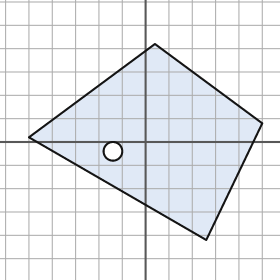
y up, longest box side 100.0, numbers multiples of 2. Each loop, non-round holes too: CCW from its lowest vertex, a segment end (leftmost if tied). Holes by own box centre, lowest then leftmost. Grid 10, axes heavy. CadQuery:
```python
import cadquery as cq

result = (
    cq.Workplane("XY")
    .moveTo(26.0, -42.0)
    .lineTo(50.0, 8.0)
    .lineTo(4.0, 42.0)
    .lineTo(-50.0, 2.0)
    .close()
    .moveTo(-14.0, -4.0)
    .circle(4.0)
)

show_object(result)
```